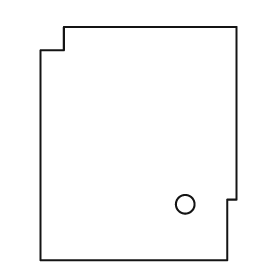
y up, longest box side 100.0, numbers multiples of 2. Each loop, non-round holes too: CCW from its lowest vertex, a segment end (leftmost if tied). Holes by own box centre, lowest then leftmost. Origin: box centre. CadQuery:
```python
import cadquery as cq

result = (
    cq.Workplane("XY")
    .moveTo(-42.0, -50.0)
    .lineTo(38.0, -50.0)
    .lineTo(38.0, -24.0)
    .lineTo(42.0, -24.0)
    .lineTo(42.0, 50.0)
    .lineTo(-32.0, 50.0)
    .lineTo(-32.0, 40.0)
    .lineTo(-42.0, 40.0)
    .close()
    .moveTo(20.0, -26.0)
    .circle(4.0)
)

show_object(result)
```